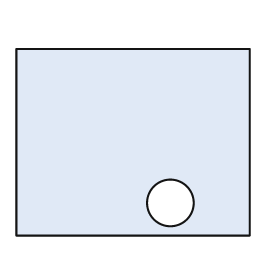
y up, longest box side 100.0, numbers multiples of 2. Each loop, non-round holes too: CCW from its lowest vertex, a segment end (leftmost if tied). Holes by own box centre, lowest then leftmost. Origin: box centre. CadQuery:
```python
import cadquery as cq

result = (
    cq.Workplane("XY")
    .moveTo(-50.0, -40.0)
    .lineTo(50.0, -40.0)
    .lineTo(50.0, 40.0)
    .lineTo(-50.0, 40.0)
    .close()
    .moveTo(16.0, -26.0)
    .circle(10.0)
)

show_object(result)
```